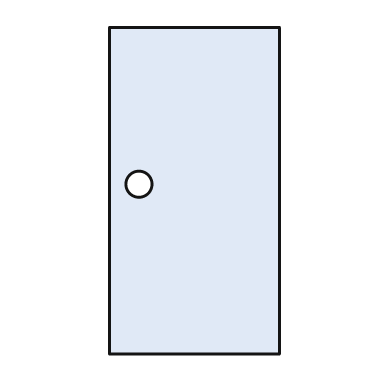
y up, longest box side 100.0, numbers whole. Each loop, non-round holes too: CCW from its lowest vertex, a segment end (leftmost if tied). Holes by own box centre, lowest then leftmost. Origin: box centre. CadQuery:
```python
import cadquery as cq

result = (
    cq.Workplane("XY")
    .moveTo(-26.0, -50.0)
    .lineTo(26.0, -50.0)
    .lineTo(26.0, 50.0)
    .lineTo(-26.0, 50.0)
    .close()
    .moveTo(-17.0, 2.0)
    .circle(4.0)
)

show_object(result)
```